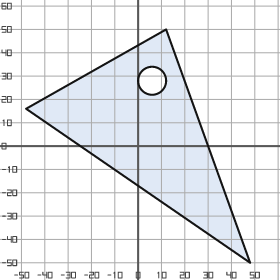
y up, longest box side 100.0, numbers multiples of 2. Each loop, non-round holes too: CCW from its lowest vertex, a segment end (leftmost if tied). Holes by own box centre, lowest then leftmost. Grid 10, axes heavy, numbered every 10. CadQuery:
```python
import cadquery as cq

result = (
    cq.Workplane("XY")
    .moveTo(48.0, -50.0)
    .lineTo(12.0, 50.0)
    .lineTo(-48.0, 16.0)
    .close()
    .moveTo(6.0, 28.0)
    .circle(6.0)
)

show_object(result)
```